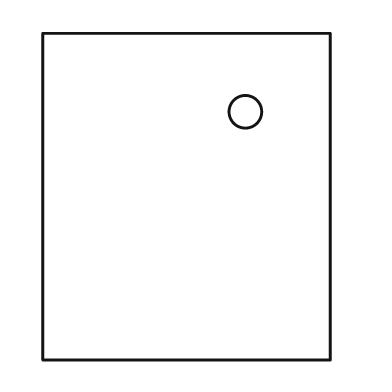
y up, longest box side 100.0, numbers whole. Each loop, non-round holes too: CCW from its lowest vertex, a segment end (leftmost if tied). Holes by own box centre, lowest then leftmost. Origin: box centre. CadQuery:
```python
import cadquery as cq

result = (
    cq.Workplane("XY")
    .moveTo(-44.0, -50.0)
    .lineTo(44.0, -50.0)
    .lineTo(44.0, 50.0)
    .lineTo(-44.0, 50.0)
    .close()
    .moveTo(18.0, 26.0)
    .circle(5.0)
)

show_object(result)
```